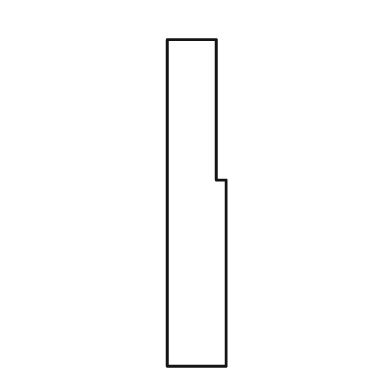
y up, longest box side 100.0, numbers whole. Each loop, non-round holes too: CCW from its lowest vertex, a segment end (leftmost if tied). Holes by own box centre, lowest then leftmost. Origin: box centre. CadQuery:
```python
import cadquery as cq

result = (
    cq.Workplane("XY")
    .moveTo(-9.0, -50.0)
    .lineTo(9.0, -50.0)
    .lineTo(9.0, 7.0)
    .lineTo(6.0, 7.0)
    .lineTo(6.0, 50.0)
    .lineTo(-9.0, 50.0)
    .close()
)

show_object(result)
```